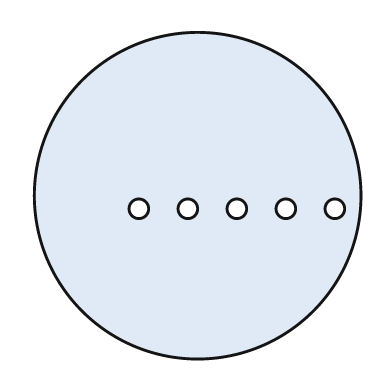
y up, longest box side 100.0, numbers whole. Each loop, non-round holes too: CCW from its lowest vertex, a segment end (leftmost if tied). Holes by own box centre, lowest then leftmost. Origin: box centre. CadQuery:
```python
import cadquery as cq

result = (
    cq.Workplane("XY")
    .moveTo(0.0, 0.0)
    .circle(50.0)
    .moveTo(-18.0, -4.0)
    .circle(3.0)
    .moveTo(-3.0, -4.0)
    .circle(3.0)
    .moveTo(12.0, -4.0)
    .circle(3.0)
    .moveTo(27.0, -4.0)
    .circle(3.0)
    .moveTo(42.0, -4.0)
    .circle(3.0)
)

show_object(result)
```